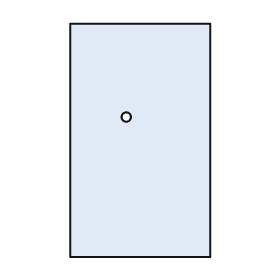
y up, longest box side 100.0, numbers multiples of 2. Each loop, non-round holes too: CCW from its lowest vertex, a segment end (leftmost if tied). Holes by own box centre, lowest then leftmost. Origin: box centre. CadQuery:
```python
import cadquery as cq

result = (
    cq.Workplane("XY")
    .moveTo(-30.0, -50.0)
    .lineTo(30.0, -50.0)
    .lineTo(30.0, 50.0)
    .lineTo(-30.0, 50.0)
    .close()
    .moveTo(-6.0, 10.0)
    .circle(2.0)
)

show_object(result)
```